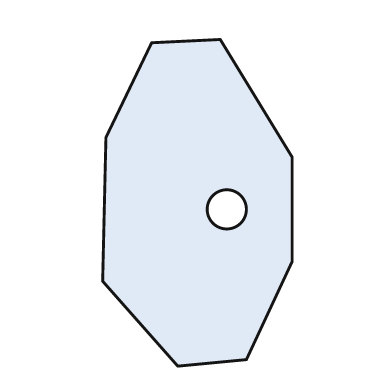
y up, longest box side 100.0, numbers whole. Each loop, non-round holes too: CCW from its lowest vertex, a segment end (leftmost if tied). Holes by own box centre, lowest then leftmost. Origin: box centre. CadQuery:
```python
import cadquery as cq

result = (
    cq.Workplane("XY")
    .moveTo(-6.0, -50.0)
    .lineTo(15.0, -48.0)
    .lineTo(29.0, -18.0)
    .lineTo(29.0, 14.0)
    .lineTo(7.0, 50.0)
    .lineTo(-14.0, 49.0)
    .lineTo(-28.0, 20.0)
    .lineTo(-29.0, -24.0)
    .close()
    .moveTo(9.0, -2.0)
    .circle(6.0)
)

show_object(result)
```